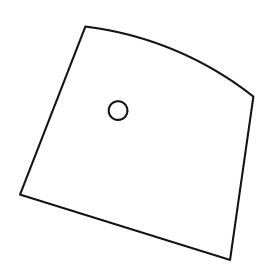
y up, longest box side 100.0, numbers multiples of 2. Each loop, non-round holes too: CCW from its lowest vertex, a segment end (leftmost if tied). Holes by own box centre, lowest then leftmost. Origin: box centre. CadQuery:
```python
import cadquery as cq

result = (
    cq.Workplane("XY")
    .moveTo(40.0, -50.0)
    .lineTo(50.0, 20.0)
    .threePointArc((16.0, 40.0), (-22.0, 50.0))
    .lineTo(-50.0, -22.0)
    .close()
    .moveTo(-8.0, 14.0)
    .circle(4.0)
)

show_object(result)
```